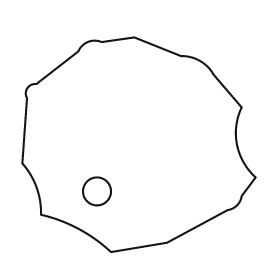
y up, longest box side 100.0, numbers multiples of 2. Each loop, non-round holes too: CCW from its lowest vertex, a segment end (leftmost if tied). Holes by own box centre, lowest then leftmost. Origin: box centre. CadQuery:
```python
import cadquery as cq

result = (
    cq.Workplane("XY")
    .moveTo(-12.0, -46.0)
    .lineTo(12.0, -42.0)
    .lineTo(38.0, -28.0)
    .threePointArc((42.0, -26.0), (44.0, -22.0))
    .lineTo(50.0, -14.0)
    .threePointArc((42.0, 0.0), (44.0, 16.0))
    .lineTo(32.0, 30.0)
    .threePointArc((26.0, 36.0), (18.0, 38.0))
    .lineTo(-2.0, 46.0)
    .lineTo(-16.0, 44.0)
    .threePointArc((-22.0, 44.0), (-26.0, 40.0))
    .lineTo(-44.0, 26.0)
    .threePointArc((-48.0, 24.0), (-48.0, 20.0))
    .lineTo(-50.0, -8.0)
    .threePointArc((-44.0, -18.0), (-42.0, -30.0))
    .threePointArc((-26.0, -36.0), (-12.0, -46.0))
    .close()
    .moveTo(-18.0, -20.0)
    .circle(6.0)
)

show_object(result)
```